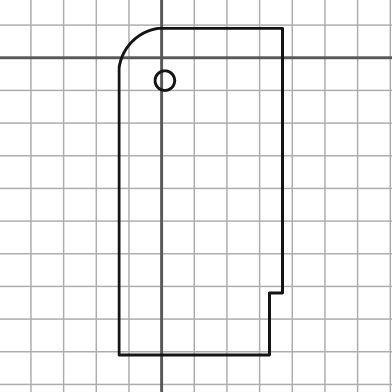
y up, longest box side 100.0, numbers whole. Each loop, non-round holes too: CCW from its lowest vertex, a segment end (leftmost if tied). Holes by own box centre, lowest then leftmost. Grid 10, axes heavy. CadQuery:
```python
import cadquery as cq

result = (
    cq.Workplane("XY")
    .moveTo(-13.0, -91.0)
    .lineTo(33.0, -91.0)
    .lineTo(33.0, -72.0)
    .lineTo(37.0, -72.0)
    .lineTo(37.0, 9.0)
    .lineTo(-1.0, 9.0)
    .threePointArc((-9.0, 5.0), (-13.0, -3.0))
    .close()
    .moveTo(1.0, -7.0)
    .circle(3.0)
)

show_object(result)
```